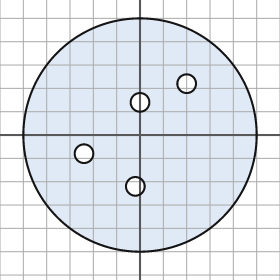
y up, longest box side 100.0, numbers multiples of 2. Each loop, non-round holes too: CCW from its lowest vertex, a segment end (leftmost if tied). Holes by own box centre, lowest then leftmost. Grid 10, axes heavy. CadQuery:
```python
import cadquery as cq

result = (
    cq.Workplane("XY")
    .moveTo(0.0, 0.0)
    .circle(50.0)
    .moveTo(-2.0, -22.0)
    .circle(4.0)
    .moveTo(-24.0, -8.0)
    .circle(4.0)
    .moveTo(0.0, 14.0)
    .circle(4.0)
    .moveTo(20.0, 22.0)
    .circle(4.0)
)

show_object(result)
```